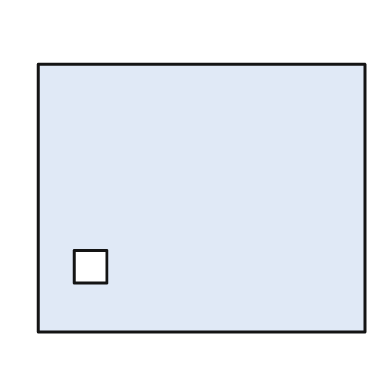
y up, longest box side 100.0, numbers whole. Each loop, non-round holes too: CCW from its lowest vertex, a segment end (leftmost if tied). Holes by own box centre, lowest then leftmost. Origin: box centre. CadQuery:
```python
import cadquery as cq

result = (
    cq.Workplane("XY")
    .moveTo(-50.0, -41.0)
    .lineTo(50.0, -41.0)
    .lineTo(50.0, 41.0)
    .lineTo(-50.0, 41.0)
    .close()
    .moveTo(-39.0, -26.0)
    .lineTo(-29.0, -26.0)
    .lineTo(-29.0, -16.0)
    .lineTo(-39.0, -16.0)
    .close()
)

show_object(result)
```